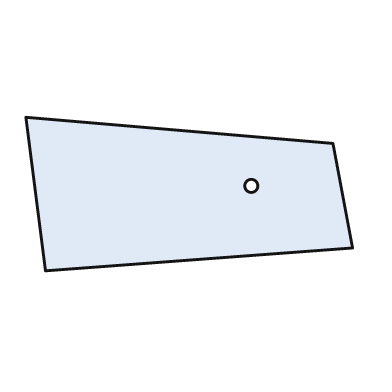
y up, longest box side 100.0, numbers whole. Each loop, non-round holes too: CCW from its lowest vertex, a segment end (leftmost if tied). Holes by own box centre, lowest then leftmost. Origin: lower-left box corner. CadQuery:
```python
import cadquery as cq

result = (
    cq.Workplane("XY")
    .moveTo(6.0, 0.0)
    .lineTo(100.0, 7.0)
    .lineTo(94.0, 39.0)
    .lineTo(0.0, 47.0)
    .close()
    .moveTo(69.0, 26.0)
    .circle(2.0)
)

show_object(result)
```